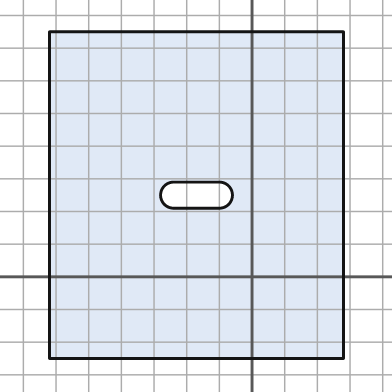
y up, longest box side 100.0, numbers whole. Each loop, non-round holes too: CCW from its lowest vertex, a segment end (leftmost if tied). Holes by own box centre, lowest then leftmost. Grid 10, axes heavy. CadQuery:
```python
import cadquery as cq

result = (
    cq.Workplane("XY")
    .moveTo(-62.0, -25.0)
    .lineTo(28.0, -25.0)
    .lineTo(28.0, 75.0)
    .lineTo(-62.0, 75.0)
    .close()
    .moveTo(-24.0, 21.0)
    .lineTo(-10.0, 21.0)
    .threePointArc((-6.0, 25.0), (-10.0, 29.0))
    .lineTo(-24.0, 29.0)
    .threePointArc((-28.0, 25.0), (-24.0, 21.0))
    .close()
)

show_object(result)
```